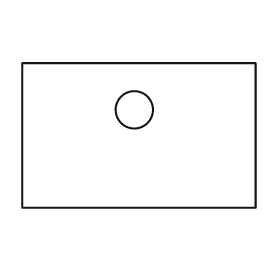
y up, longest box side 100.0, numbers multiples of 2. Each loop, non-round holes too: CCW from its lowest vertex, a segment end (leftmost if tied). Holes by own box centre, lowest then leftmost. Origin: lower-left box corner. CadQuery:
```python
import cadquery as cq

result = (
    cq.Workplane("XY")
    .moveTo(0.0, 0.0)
    .lineTo(100.0, 0.0)
    .lineTo(100.0, 62.0)
    .lineTo(0.0, 62.0)
    .close()
    .moveTo(48.0, 42.0)
    .circle(8.0)
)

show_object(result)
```